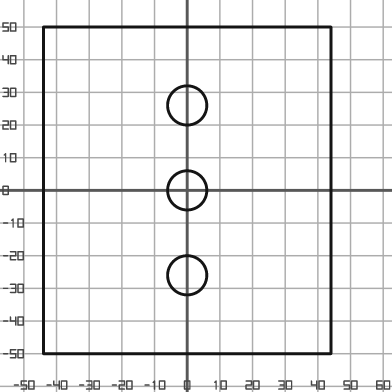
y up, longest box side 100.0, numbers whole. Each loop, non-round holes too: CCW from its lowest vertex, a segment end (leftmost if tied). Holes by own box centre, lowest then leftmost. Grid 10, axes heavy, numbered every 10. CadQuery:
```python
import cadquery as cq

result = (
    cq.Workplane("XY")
    .moveTo(-44.0, -50.0)
    .lineTo(44.0, -50.0)
    .lineTo(44.0, 50.0)
    .lineTo(-44.0, 50.0)
    .close()
    .moveTo(0.0, -26.0)
    .circle(6.0)
    .moveTo(0.0, 0.0)
    .circle(6.0)
    .moveTo(0.0, 26.0)
    .circle(6.0)
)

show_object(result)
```